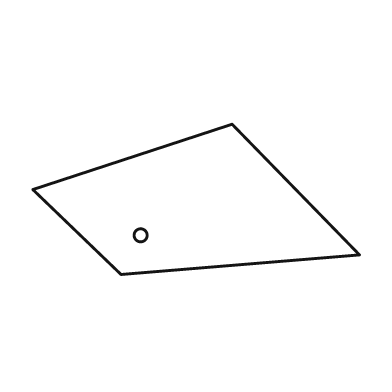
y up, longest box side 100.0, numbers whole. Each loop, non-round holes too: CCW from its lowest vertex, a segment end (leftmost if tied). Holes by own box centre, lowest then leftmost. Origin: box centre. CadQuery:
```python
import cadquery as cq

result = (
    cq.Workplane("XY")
    .moveTo(-23.0, -23.0)
    .lineTo(50.0, -17.0)
    .lineTo(11.0, 23.0)
    .lineTo(-50.0, 3.0)
    .close()
    .moveTo(-17.0, -11.0)
    .circle(2.0)
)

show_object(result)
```